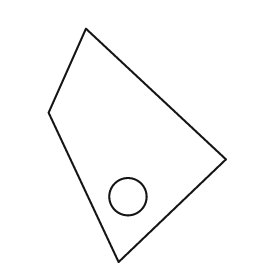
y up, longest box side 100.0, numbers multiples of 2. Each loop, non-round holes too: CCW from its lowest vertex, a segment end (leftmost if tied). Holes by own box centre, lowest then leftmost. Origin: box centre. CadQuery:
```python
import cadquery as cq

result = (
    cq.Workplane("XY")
    .moveTo(-8.0, -50.0)
    .lineTo(38.0, -6.0)
    .lineTo(-22.0, 50.0)
    .lineTo(-38.0, 14.0)
    .close()
    .moveTo(-4.0, -22.0)
    .circle(8.0)
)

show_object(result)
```